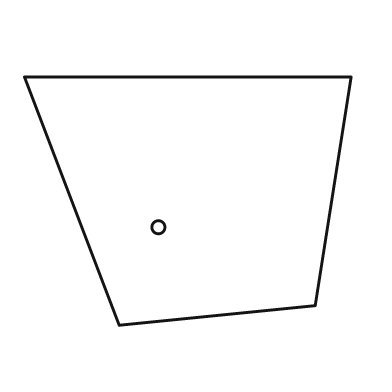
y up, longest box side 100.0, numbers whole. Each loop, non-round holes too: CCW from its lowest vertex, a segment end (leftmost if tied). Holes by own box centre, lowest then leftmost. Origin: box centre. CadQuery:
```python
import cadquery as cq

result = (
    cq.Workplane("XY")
    .moveTo(-21.0, -38.0)
    .lineTo(39.0, -32.0)
    .lineTo(50.0, 38.0)
    .lineTo(-50.0, 38.0)
    .close()
    .moveTo(-9.0, -8.0)
    .circle(2.0)
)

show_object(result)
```